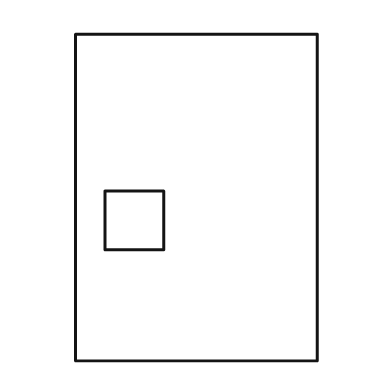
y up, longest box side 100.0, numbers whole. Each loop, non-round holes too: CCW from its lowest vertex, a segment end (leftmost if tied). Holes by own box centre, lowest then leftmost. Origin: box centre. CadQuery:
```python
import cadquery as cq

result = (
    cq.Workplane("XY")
    .moveTo(-37.0, -50.0)
    .lineTo(37.0, -50.0)
    .lineTo(37.0, 50.0)
    .lineTo(-37.0, 50.0)
    .close()
    .moveTo(-28.0, -16.0)
    .lineTo(-10.0, -16.0)
    .lineTo(-10.0, 2.0)
    .lineTo(-28.0, 2.0)
    .close()
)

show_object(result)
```